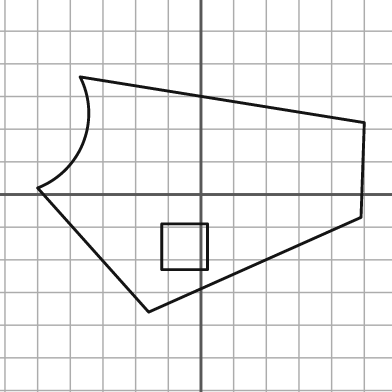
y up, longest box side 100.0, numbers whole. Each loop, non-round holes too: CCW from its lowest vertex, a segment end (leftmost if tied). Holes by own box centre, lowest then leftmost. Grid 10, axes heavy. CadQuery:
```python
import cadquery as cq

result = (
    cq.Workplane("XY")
    .moveTo(-16.0, -36.0)
    .lineTo(49.0, -7.0)
    .lineTo(50.0, 22.0)
    .lineTo(-37.0, 36.0)
    .threePointArc((-36.0, 16.0), (-50.0, 2.0))
    .close()
    .moveTo(-12.0, -23.0)
    .lineTo(2.0, -23.0)
    .lineTo(2.0, -9.0)
    .lineTo(-12.0, -9.0)
    .close()
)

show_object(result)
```